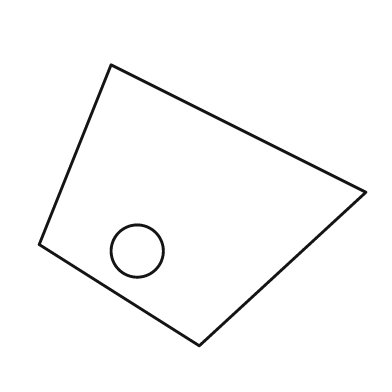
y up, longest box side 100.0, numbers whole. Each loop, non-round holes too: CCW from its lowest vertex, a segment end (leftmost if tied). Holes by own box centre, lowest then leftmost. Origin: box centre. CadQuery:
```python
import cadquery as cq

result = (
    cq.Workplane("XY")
    .moveTo(-1.0, -43.0)
    .lineTo(50.0, 4.0)
    .lineTo(-28.0, 43.0)
    .lineTo(-50.0, -12.0)
    .close()
    .moveTo(-20.0, -14.0)
    .circle(8.0)
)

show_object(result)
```